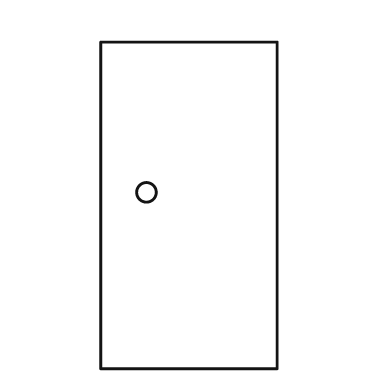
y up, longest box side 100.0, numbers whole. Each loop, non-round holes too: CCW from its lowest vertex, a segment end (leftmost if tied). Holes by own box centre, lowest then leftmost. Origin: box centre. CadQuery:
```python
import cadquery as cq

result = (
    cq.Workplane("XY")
    .moveTo(-27.0, -50.0)
    .lineTo(27.0, -50.0)
    .lineTo(27.0, 50.0)
    .lineTo(-27.0, 50.0)
    .close()
    .moveTo(-13.0, 4.0)
    .circle(3.0)
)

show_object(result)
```